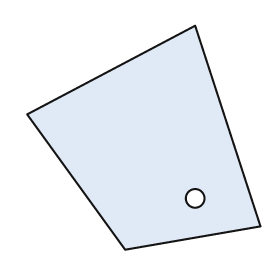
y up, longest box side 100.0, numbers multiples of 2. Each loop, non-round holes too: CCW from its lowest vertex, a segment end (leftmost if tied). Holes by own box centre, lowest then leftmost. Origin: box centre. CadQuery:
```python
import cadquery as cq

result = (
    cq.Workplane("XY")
    .moveTo(-8.0, -48.0)
    .lineTo(50.0, -38.0)
    .lineTo(22.0, 48.0)
    .lineTo(-50.0, 10.0)
    .close()
    .moveTo(22.0, -26.0)
    .circle(4.0)
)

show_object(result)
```